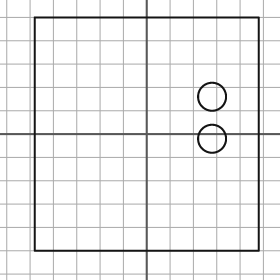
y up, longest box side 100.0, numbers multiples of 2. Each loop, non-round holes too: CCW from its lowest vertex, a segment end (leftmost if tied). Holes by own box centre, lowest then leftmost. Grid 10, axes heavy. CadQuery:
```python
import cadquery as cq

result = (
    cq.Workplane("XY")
    .moveTo(-48.0, -50.0)
    .lineTo(48.0, -50.0)
    .lineTo(48.0, 50.0)
    .lineTo(-48.0, 50.0)
    .close()
    .moveTo(28.0, -2.0)
    .circle(6.0)
    .moveTo(28.0, 16.0)
    .circle(6.0)
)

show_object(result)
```